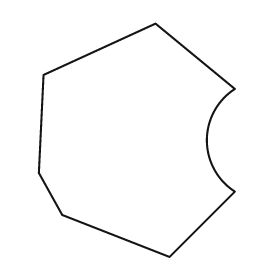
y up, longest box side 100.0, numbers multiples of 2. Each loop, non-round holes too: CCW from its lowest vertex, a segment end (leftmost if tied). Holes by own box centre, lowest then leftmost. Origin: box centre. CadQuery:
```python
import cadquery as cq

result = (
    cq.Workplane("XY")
    .moveTo(14.0, -50.0)
    .lineTo(42.0, -22.0)
    .threePointArc((30.0, 0.0), (42.0, 22.0))
    .lineTo(8.0, 50.0)
    .lineTo(-40.0, 28.0)
    .lineTo(-42.0, -14.0)
    .lineTo(-32.0, -32.0)
    .close()
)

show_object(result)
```